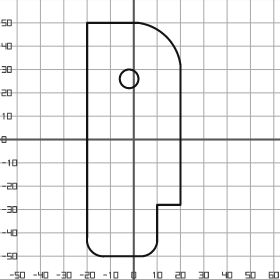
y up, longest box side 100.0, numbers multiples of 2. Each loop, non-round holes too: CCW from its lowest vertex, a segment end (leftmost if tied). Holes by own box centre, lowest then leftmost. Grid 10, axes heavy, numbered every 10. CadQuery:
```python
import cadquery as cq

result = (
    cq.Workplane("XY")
    .moveTo(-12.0, -50.0)
    .lineTo(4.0, -50.0)
    .threePointArc((8.0, -48.0), (10.0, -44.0))
    .lineTo(10.0, -28.0)
    .lineTo(20.0, -28.0)
    .lineTo(20.0, 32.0)
    .threePointArc((14.0, 44.0), (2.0, 50.0))
    .lineTo(-20.0, 50.0)
    .lineTo(-20.0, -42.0)
    .threePointArc((-18.0, -48.0), (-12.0, -50.0))
    .close()
    .moveTo(-2.0, 26.0)
    .circle(4.0)
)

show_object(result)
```